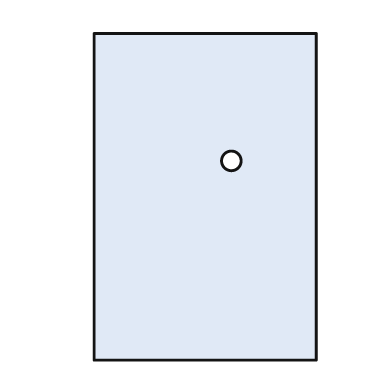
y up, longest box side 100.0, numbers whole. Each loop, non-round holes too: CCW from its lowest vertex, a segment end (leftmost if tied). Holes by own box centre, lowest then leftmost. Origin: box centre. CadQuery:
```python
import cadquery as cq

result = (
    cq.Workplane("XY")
    .moveTo(-34.0, -50.0)
    .lineTo(34.0, -50.0)
    .lineTo(34.0, 50.0)
    .lineTo(-34.0, 50.0)
    .close()
    .moveTo(8.0, 11.0)
    .circle(3.0)
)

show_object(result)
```